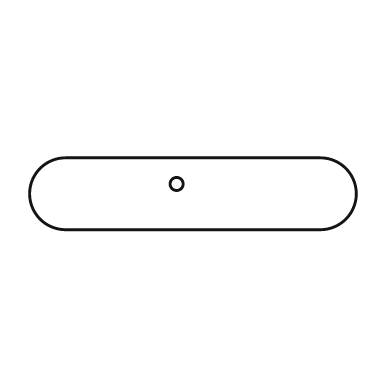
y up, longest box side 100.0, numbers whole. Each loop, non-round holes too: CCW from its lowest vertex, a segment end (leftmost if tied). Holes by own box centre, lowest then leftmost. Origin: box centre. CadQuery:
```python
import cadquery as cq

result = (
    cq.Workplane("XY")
    .moveTo(-39.0, -11.0)
    .lineTo(39.0, -11.0)
    .threePointArc((50.0, 0.0), (39.0, 11.0))
    .lineTo(-39.0, 11.0)
    .threePointArc((-50.0, 0.0), (-39.0, -11.0))
    .close()
    .moveTo(-5.0, 3.0)
    .circle(2.0)
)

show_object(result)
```